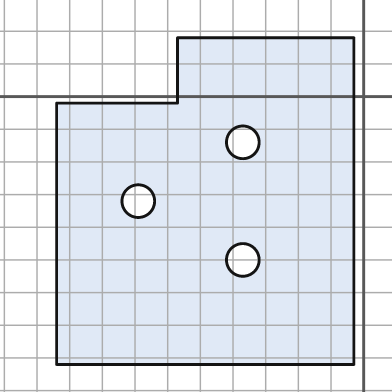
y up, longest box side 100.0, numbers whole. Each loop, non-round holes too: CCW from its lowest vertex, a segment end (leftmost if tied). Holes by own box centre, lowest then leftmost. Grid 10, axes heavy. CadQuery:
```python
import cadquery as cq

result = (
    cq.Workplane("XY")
    .moveTo(-94.0, -82.0)
    .lineTo(-3.0, -82.0)
    .lineTo(-3.0, 18.0)
    .lineTo(-57.0, 18.0)
    .lineTo(-57.0, -2.0)
    .lineTo(-94.0, -2.0)
    .close()
    .moveTo(-37.0, -50.0)
    .circle(5.0)
    .moveTo(-69.0, -32.0)
    .circle(5.0)
    .moveTo(-37.0, -14.0)
    .circle(5.0)
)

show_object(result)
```